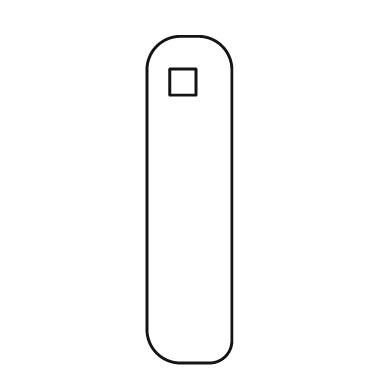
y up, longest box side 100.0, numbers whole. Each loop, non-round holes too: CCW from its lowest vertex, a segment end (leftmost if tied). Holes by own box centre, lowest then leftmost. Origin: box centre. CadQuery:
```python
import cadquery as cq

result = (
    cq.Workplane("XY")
    .moveTo(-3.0, -50.0)
    .lineTo(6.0, -50.0)
    .threePointArc((11.0, -48.0), (13.0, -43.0))
    .lineTo(13.0, 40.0)
    .threePointArc((10.0, 47.0), (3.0, 50.0))
    .lineTo(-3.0, 50.0)
    .threePointArc((-10.0, 47.0), (-13.0, 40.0))
    .lineTo(-13.0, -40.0)
    .threePointArc((-10.0, -47.0), (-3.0, -50.0))
    .close()
    .moveTo(-6.0, 32.0)
    .lineTo(2.0, 32.0)
    .lineTo(2.0, 40.0)
    .lineTo(-6.0, 40.0)
    .close()
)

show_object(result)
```